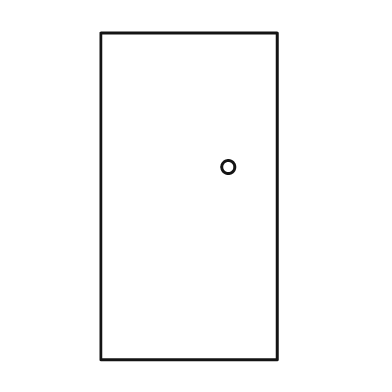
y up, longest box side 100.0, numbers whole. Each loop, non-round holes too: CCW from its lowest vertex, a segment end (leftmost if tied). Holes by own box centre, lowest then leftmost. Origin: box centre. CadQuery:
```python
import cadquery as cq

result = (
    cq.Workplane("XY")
    .moveTo(-27.0, -50.0)
    .lineTo(27.0, -50.0)
    .lineTo(27.0, 50.0)
    .lineTo(-27.0, 50.0)
    .close()
    .moveTo(12.0, 9.0)
    .circle(2.0)
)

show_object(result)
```